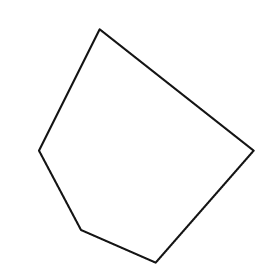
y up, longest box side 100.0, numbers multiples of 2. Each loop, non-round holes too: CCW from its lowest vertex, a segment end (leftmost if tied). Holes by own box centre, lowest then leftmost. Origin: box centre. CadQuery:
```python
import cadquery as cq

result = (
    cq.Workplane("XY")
    .moveTo(4.0, -50.0)
    .lineTo(46.0, -2.0)
    .lineTo(-20.0, 50.0)
    .lineTo(-46.0, -2.0)
    .lineTo(-28.0, -36.0)
    .close()
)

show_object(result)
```